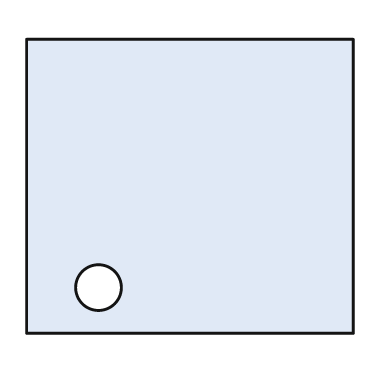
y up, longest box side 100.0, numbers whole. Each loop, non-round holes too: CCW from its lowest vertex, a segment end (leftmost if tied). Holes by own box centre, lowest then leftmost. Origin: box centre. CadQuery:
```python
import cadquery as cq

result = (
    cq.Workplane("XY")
    .moveTo(-50.0, -45.0)
    .lineTo(50.0, -45.0)
    .lineTo(50.0, 45.0)
    .lineTo(-50.0, 45.0)
    .close()
    .moveTo(-28.0, -31.0)
    .circle(7.0)
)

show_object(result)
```